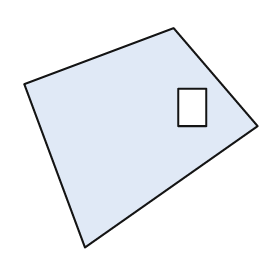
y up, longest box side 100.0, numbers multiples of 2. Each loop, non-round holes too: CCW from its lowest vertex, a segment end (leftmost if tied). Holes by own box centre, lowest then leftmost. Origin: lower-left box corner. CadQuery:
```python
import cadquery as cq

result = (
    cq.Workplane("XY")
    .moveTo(26.0, 0.0)
    .lineTo(100.0, 52.0)
    .lineTo(64.0, 94.0)
    .lineTo(0.0, 70.0)
    .close()
    .moveTo(66.0, 52.0)
    .lineTo(78.0, 52.0)
    .lineTo(78.0, 68.0)
    .lineTo(66.0, 68.0)
    .close()
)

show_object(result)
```